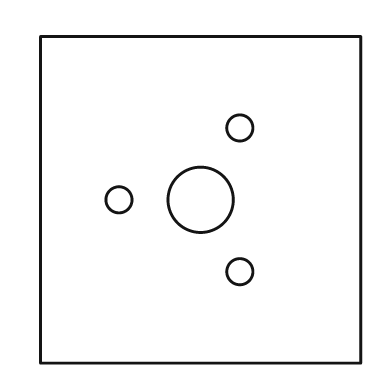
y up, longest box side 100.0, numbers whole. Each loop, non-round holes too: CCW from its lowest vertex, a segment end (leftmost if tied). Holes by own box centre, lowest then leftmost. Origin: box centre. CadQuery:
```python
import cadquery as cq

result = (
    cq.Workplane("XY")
    .moveTo(-49.0, -50.0)
    .lineTo(49.0, -50.0)
    .lineTo(49.0, 50.0)
    .lineTo(-49.0, 50.0)
    .close()
    .moveTo(12.0, -22.0)
    .circle(4.0)
    .moveTo(-25.0, 0.0)
    .circle(4.0)
    .moveTo(0.0, 0.0)
    .circle(10.0)
    .moveTo(12.0, 22.0)
    .circle(4.0)
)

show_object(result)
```